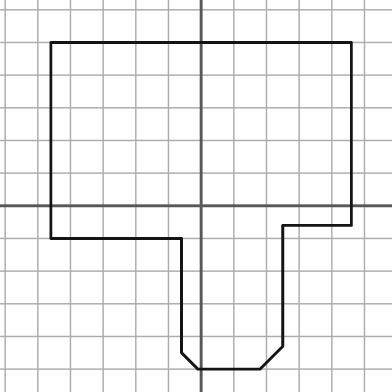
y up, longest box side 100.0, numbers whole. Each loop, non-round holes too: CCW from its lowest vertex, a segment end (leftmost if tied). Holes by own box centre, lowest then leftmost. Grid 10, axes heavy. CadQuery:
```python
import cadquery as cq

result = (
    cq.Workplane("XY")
    .moveTo(-1.0, -50.0)
    .lineTo(18.0, -50.0)
    .lineTo(25.0, -43.0)
    .lineTo(25.0, -6.0)
    .lineTo(46.0, -6.0)
    .lineTo(46.0, 50.0)
    .lineTo(-46.0, 50.0)
    .lineTo(-46.0, -10.0)
    .lineTo(-6.0, -10.0)
    .lineTo(-6.0, -45.0)
    .close()
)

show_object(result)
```